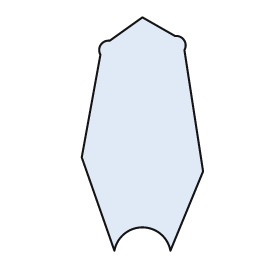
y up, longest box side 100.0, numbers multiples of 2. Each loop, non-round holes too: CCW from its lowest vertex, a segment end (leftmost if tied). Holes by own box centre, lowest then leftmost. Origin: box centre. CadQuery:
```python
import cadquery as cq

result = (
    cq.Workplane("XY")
    .moveTo(-12.0, -50.0)
    .threePointArc((0.0, -40.0), (12.0, -50.0))
    .lineTo(26.0, -16.0)
    .lineTo(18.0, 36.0)
    .threePointArc((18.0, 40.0), (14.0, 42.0))
    .lineTo(0.0, 50.0)
    .lineTo(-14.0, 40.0)
    .threePointArc((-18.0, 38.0), (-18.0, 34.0))
    .lineTo(-26.0, -10.0)
    .close()
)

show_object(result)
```